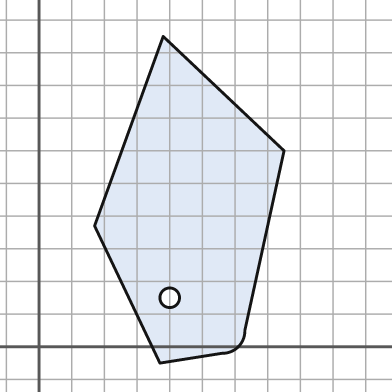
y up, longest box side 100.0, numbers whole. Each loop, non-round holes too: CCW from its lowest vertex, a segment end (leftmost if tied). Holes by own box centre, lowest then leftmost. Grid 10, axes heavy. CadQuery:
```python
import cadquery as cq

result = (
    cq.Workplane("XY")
    .moveTo(37.0, -5.0)
    .lineTo(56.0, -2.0)
    .threePointArc((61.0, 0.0), (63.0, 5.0))
    .lineTo(75.0, 60.0)
    .lineTo(38.0, 95.0)
    .lineTo(17.0, 37.0)
    .close()
    .moveTo(40.0, 15.0)
    .circle(3.0)
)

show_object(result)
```